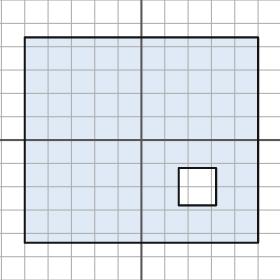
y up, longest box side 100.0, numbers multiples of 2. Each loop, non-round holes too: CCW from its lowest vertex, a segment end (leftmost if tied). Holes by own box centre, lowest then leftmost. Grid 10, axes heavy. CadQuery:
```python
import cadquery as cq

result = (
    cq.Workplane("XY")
    .moveTo(-50.0, -44.0)
    .lineTo(50.0, -44.0)
    .lineTo(50.0, 44.0)
    .lineTo(-50.0, 44.0)
    .close()
    .moveTo(16.0, -28.0)
    .lineTo(32.0, -28.0)
    .lineTo(32.0, -12.0)
    .lineTo(16.0, -12.0)
    .close()
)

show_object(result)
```